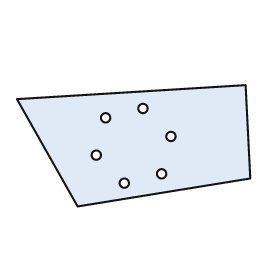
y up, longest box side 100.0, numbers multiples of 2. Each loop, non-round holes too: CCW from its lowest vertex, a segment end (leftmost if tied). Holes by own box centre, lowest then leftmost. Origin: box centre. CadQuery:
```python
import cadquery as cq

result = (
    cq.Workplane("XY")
    .moveTo(-24.0, -26.0)
    .lineTo(50.0, -14.0)
    .lineTo(48.0, 26.0)
    .lineTo(-50.0, 20.0)
    .close()
    .moveTo(-4.0, -16.0)
    .circle(2.0)
    .moveTo(12.0, -12.0)
    .circle(2.0)
    .moveTo(-16.0, -4.0)
    .circle(2.0)
    .moveTo(16.0, 4.0)
    .circle(2.0)
    .moveTo(-12.0, 12.0)
    .circle(2.0)
    .moveTo(4.0, 16.0)
    .circle(2.0)
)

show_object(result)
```